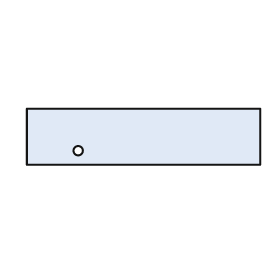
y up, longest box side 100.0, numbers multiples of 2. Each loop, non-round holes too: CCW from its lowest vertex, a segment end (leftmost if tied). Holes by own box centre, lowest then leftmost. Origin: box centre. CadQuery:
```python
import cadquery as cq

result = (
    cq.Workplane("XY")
    .moveTo(-50.0, -12.0)
    .lineTo(50.0, -12.0)
    .lineTo(50.0, 12.0)
    .lineTo(-50.0, 12.0)
    .close()
    .moveTo(-28.0, -6.0)
    .circle(2.0)
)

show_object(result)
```